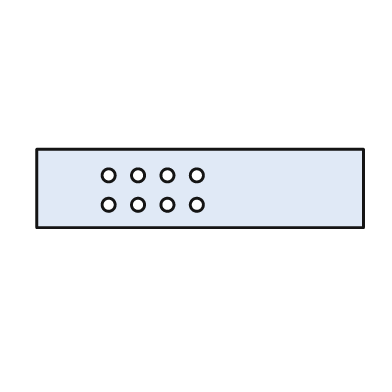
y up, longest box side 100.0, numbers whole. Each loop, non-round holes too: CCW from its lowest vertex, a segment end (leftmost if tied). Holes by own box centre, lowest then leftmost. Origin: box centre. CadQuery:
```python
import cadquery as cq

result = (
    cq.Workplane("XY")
    .moveTo(-50.0, -12.0)
    .lineTo(50.0, -12.0)
    .lineTo(50.0, 12.0)
    .lineTo(-50.0, 12.0)
    .close()
    .moveTo(-28.0, -5.0)
    .circle(2.0)
    .moveTo(-19.0, -5.0)
    .circle(2.0)
    .moveTo(-10.0, -5.0)
    .circle(2.0)
    .moveTo(-1.0, -5.0)
    .circle(2.0)
    .moveTo(-28.0, 4.0)
    .circle(2.0)
    .moveTo(-19.0, 4.0)
    .circle(2.0)
    .moveTo(-10.0, 4.0)
    .circle(2.0)
    .moveTo(-1.0, 4.0)
    .circle(2.0)
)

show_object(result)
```